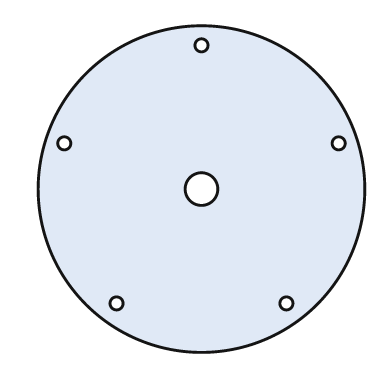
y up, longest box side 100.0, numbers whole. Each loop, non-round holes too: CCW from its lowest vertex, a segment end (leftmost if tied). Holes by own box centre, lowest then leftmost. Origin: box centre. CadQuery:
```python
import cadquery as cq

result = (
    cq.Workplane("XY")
    .moveTo(0.0, 0.0)
    .circle(50.0)
    .moveTo(-26.0, -35.0)
    .circle(2.0)
    .moveTo(26.0, -35.0)
    .circle(2.0)
    .moveTo(0.0, 0.0)
    .circle(5.0)
    .moveTo(-42.0, 14.0)
    .circle(2.0)
    .moveTo(42.0, 14.0)
    .circle(2.0)
    .moveTo(0.0, 44.0)
    .circle(2.0)
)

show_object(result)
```